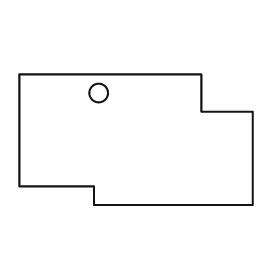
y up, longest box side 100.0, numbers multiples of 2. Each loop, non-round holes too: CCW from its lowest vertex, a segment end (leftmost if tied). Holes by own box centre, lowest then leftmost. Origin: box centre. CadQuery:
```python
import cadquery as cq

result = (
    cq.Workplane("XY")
    .moveTo(-18.0, -28.0)
    .lineTo(50.0, -28.0)
    .lineTo(50.0, 12.0)
    .lineTo(28.0, 12.0)
    .lineTo(28.0, 28.0)
    .lineTo(-50.0, 28.0)
    .lineTo(-50.0, -20.0)
    .lineTo(-18.0, -20.0)
    .close()
    .moveTo(-16.0, 20.0)
    .circle(4.0)
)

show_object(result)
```